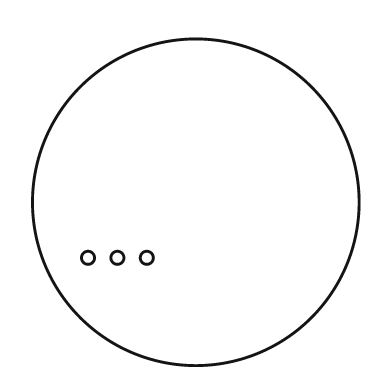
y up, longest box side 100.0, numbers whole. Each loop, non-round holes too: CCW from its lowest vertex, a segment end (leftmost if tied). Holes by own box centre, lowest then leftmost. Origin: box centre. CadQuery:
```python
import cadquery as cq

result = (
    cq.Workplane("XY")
    .moveTo(0.0, 0.0)
    .circle(50.0)
    .moveTo(-33.0, -17.0)
    .circle(2.0)
    .moveTo(-24.0, -17.0)
    .circle(2.0)
    .moveTo(-15.0, -17.0)
    .circle(2.0)
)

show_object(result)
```